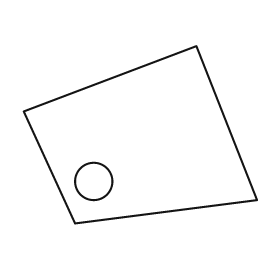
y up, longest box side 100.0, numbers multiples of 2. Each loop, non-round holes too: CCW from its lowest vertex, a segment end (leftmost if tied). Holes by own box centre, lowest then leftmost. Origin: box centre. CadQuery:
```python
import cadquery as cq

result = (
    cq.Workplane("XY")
    .moveTo(-28.0, -38.0)
    .lineTo(50.0, -28.0)
    .lineTo(24.0, 38.0)
    .lineTo(-50.0, 10.0)
    .close()
    .moveTo(-20.0, -20.0)
    .circle(8.0)
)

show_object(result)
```